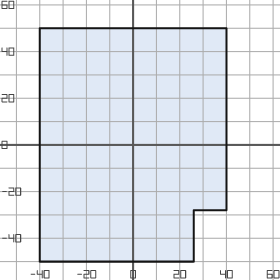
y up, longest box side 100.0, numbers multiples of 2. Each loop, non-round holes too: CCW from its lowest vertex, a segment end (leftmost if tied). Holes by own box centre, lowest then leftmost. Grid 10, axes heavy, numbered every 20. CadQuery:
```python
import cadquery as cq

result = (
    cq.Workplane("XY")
    .moveTo(-40.0, -50.0)
    .lineTo(26.0, -50.0)
    .lineTo(26.0, -28.0)
    .lineTo(40.0, -28.0)
    .lineTo(40.0, 50.0)
    .lineTo(-40.0, 50.0)
    .close()
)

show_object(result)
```